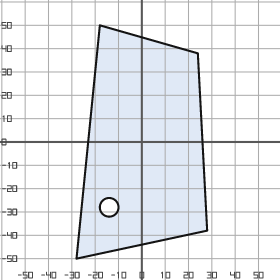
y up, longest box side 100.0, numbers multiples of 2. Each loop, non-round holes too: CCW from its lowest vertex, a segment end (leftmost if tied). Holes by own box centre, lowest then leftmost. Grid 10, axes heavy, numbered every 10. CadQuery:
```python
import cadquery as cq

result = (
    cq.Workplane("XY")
    .moveTo(-28.0, -50.0)
    .lineTo(28.0, -38.0)
    .lineTo(24.0, 38.0)
    .lineTo(-18.0, 50.0)
    .close()
    .moveTo(-14.0, -28.0)
    .circle(4.0)
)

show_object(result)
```